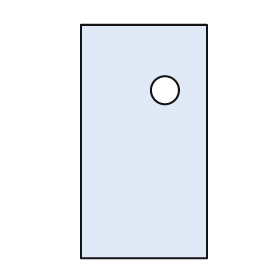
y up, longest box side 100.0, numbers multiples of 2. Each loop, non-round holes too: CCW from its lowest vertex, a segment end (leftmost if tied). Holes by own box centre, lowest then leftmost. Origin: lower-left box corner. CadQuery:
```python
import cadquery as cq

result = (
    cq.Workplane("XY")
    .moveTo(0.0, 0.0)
    .lineTo(54.0, 0.0)
    .lineTo(54.0, 100.0)
    .lineTo(0.0, 100.0)
    .close()
    .moveTo(36.0, 72.0)
    .circle(6.0)
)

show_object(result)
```